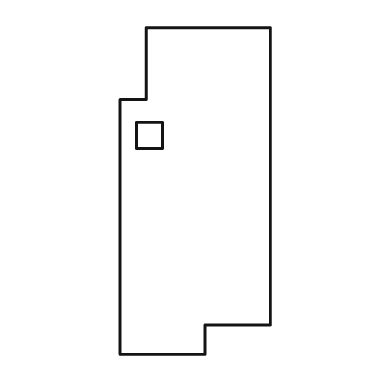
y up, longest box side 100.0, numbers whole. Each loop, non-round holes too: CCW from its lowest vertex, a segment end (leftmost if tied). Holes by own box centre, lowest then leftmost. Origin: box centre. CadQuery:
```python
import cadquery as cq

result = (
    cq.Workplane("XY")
    .moveTo(-23.0, -50.0)
    .lineTo(3.0, -50.0)
    .lineTo(3.0, -41.0)
    .lineTo(23.0, -41.0)
    .lineTo(23.0, 50.0)
    .lineTo(-15.0, 50.0)
    .lineTo(-15.0, 28.0)
    .lineTo(-23.0, 28.0)
    .close()
    .moveTo(-18.0, 13.0)
    .lineTo(-10.0, 13.0)
    .lineTo(-10.0, 21.0)
    .lineTo(-18.0, 21.0)
    .close()
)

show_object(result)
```